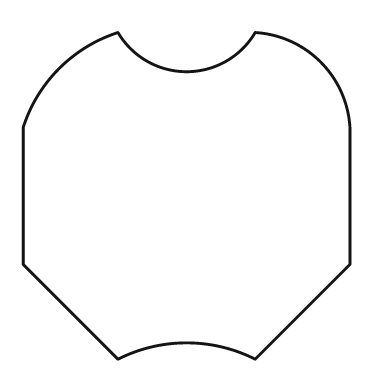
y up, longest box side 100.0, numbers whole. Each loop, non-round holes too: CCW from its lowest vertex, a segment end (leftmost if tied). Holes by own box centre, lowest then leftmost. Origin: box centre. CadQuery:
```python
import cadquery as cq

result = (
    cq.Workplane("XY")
    .moveTo(-21.0, -50.0)
    .threePointArc((0.0, -45.0), (21.0, -50.0))
    .lineTo(50.0, -21.0)
    .lineTo(50.0, 21.0)
    .threePointArc((41.0, 41.0), (21.0, 50.0))
    .threePointArc((0.0, 38.0), (-21.0, 50.0))
    .threePointArc((-39.0, 39.0), (-50.0, 21.0))
    .lineTo(-50.0, -21.0)
    .close()
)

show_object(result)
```